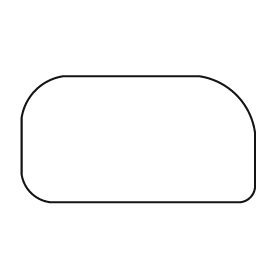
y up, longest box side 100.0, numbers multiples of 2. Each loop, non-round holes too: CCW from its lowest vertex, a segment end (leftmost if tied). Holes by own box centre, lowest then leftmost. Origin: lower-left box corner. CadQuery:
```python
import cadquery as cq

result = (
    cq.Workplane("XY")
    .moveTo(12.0, 0.0)
    .lineTo(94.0, 0.0)
    .threePointArc((98.0, 2.0), (100.0, 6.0))
    .lineTo(100.0, 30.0)
    .threePointArc((92.0, 46.0), (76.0, 54.0))
    .lineTo(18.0, 54.0)
    .threePointArc((6.0, 48.0), (0.0, 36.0))
    .lineTo(0.0, 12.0)
    .threePointArc((4.0, 4.0), (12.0, 0.0))
    .close()
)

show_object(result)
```